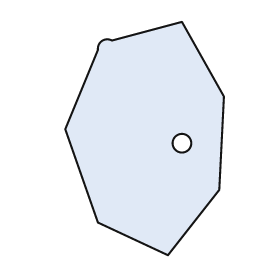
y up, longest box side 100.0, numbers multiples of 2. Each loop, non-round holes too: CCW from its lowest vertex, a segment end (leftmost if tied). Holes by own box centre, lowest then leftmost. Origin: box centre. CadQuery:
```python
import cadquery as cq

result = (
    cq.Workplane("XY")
    .moveTo(10.0, -50.0)
    .lineTo(32.0, -22.0)
    .lineTo(34.0, 18.0)
    .lineTo(16.0, 50.0)
    .lineTo(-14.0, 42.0)
    .threePointArc((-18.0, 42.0), (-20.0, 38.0))
    .lineTo(-34.0, 4.0)
    .lineTo(-20.0, -36.0)
    .close()
    .moveTo(16.0, -2.0)
    .circle(4.0)
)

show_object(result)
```